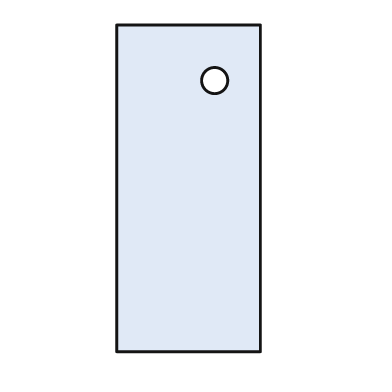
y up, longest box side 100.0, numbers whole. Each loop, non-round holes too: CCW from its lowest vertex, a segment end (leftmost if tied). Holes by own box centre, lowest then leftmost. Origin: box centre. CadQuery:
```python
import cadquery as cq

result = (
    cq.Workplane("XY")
    .moveTo(-22.0, -50.0)
    .lineTo(22.0, -50.0)
    .lineTo(22.0, 50.0)
    .lineTo(-22.0, 50.0)
    .close()
    .moveTo(8.0, 33.0)
    .circle(4.0)
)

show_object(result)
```